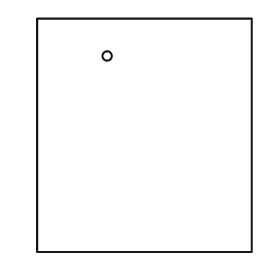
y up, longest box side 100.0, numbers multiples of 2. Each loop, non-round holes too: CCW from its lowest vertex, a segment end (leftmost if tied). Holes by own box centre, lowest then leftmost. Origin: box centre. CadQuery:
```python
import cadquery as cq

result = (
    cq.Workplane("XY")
    .moveTo(-46.0, -50.0)
    .lineTo(46.0, -50.0)
    .lineTo(46.0, 50.0)
    .lineTo(-46.0, 50.0)
    .close()
    .moveTo(-16.0, 34.0)
    .circle(2.0)
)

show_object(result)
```